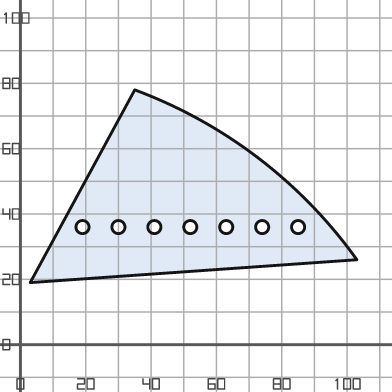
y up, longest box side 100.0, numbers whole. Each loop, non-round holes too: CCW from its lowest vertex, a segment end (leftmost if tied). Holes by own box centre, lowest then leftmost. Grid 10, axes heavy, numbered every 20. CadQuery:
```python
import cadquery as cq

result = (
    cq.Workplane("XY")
    .moveTo(3.0, 19.0)
    .lineTo(103.0, 26.0)
    .threePointArc((73.0, 57.0), (35.0, 78.0))
    .close()
    .moveTo(19.0, 36.0)
    .circle(2.0)
    .moveTo(30.0, 36.0)
    .circle(2.0)
    .moveTo(41.0, 36.0)
    .circle(2.0)
    .moveTo(52.0, 36.0)
    .circle(2.0)
    .moveTo(63.0, 36.0)
    .circle(2.0)
    .moveTo(74.0, 36.0)
    .circle(2.0)
    .moveTo(85.0, 36.0)
    .circle(2.0)
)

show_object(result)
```